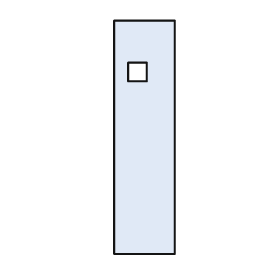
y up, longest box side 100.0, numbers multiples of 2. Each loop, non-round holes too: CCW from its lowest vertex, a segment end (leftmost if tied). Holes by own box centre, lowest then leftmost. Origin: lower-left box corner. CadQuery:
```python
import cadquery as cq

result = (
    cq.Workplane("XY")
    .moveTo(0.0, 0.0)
    .lineTo(26.0, 0.0)
    .lineTo(26.0, 100.0)
    .lineTo(0.0, 100.0)
    .close()
    .moveTo(6.0, 74.0)
    .lineTo(14.0, 74.0)
    .lineTo(14.0, 82.0)
    .lineTo(6.0, 82.0)
    .close()
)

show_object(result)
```